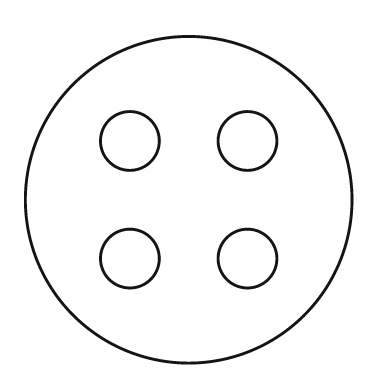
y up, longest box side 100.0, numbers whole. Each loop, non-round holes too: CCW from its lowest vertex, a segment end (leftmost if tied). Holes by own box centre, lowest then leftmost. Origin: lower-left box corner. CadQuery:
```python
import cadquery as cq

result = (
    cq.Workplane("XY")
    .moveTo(50.0, 50.0)
    .circle(50.0)
    .moveTo(32.0, 32.0)
    .circle(9.0)
    .moveTo(68.0, 32.0)
    .circle(9.0)
    .moveTo(32.0, 68.0)
    .circle(9.0)
    .moveTo(68.0, 68.0)
    .circle(9.0)
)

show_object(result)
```